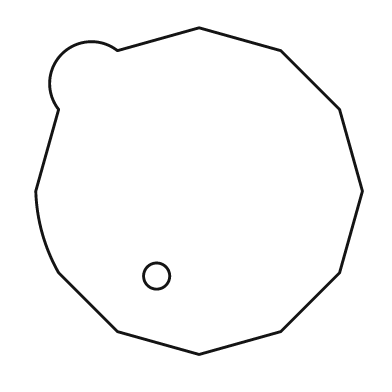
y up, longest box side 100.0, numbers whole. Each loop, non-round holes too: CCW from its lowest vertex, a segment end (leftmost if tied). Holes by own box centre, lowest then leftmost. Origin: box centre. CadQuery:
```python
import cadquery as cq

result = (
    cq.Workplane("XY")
    .moveTo(0.0, -50.0)
    .lineTo(25.0, -43.0)
    .lineTo(43.0, -25.0)
    .lineTo(50.0, 0.0)
    .lineTo(43.0, 25.0)
    .lineTo(25.0, 43.0)
    .lineTo(0.0, 50.0)
    .lineTo(-25.0, 43.0)
    .threePointArc((-42.0, 42.0), (-43.0, 25.0))
    .lineTo(-50.0, 0.0)
    .threePointArc((-48.0, -13.0), (-43.0, -25.0))
    .lineTo(-25.0, -43.0)
    .close()
    .moveTo(-13.0, -26.0)
    .circle(4.0)
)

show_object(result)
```